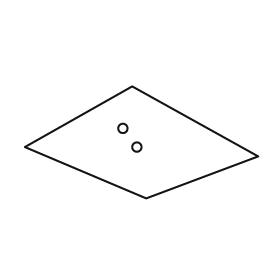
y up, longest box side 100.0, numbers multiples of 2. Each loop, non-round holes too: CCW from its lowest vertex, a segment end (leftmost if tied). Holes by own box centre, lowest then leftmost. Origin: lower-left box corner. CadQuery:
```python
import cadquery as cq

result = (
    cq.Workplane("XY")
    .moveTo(52.0, 0.0)
    .lineTo(100.0, 18.0)
    .lineTo(46.0, 48.0)
    .lineTo(0.0, 22.0)
    .close()
    .moveTo(48.0, 22.0)
    .circle(2.0)
    .moveTo(42.0, 30.0)
    .circle(2.0)
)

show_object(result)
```